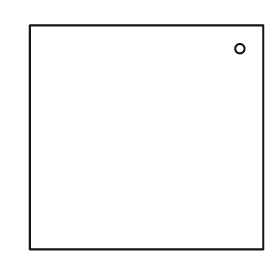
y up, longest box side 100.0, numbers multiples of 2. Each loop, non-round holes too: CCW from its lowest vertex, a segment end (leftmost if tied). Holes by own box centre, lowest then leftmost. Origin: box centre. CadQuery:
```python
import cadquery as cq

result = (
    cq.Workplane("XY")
    .moveTo(-50.0, -48.0)
    .lineTo(50.0, -48.0)
    .lineTo(50.0, 48.0)
    .lineTo(-50.0, 48.0)
    .close()
    .moveTo(40.0, 38.0)
    .circle(2.0)
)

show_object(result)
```